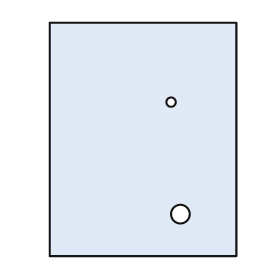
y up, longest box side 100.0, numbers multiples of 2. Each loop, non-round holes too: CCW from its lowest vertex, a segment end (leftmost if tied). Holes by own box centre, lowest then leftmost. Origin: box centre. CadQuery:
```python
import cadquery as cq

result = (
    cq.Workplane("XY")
    .moveTo(-40.0, -50.0)
    .lineTo(40.0, -50.0)
    .lineTo(40.0, 50.0)
    .lineTo(-40.0, 50.0)
    .close()
    .moveTo(16.0, -32.0)
    .circle(4.0)
    .moveTo(12.0, 16.0)
    .circle(2.0)
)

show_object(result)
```